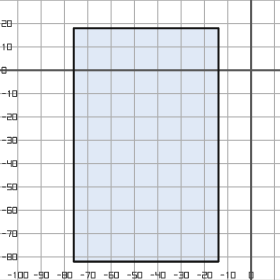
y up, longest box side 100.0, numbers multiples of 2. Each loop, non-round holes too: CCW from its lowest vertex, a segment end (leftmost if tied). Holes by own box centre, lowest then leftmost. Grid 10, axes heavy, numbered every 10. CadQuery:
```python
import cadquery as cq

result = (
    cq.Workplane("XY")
    .moveTo(-76.0, -82.0)
    .lineTo(-14.0, -82.0)
    .lineTo(-14.0, 18.0)
    .lineTo(-76.0, 18.0)
    .close()
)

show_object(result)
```